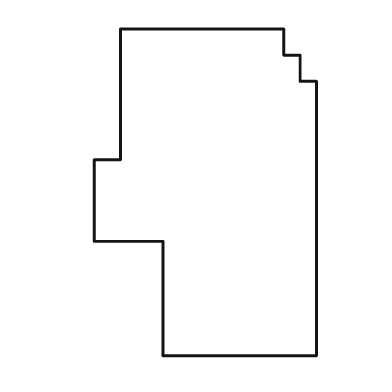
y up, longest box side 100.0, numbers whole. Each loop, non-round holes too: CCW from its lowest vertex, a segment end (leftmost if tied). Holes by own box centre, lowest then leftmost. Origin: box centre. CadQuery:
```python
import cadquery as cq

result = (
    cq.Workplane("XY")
    .moveTo(-13.0, -50.0)
    .lineTo(34.0, -50.0)
    .lineTo(34.0, 34.0)
    .lineTo(29.0, 34.0)
    .lineTo(29.0, 42.0)
    .lineTo(24.0, 42.0)
    .lineTo(24.0, 50.0)
    .lineTo(-26.0, 50.0)
    .lineTo(-26.0, 10.0)
    .lineTo(-34.0, 10.0)
    .lineTo(-34.0, -15.0)
    .lineTo(-13.0, -15.0)
    .close()
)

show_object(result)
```